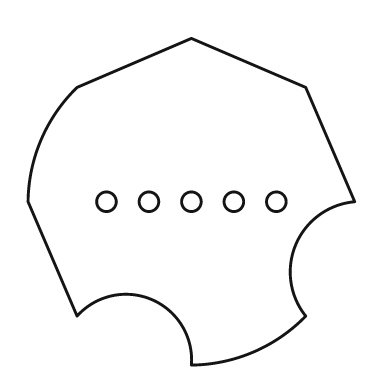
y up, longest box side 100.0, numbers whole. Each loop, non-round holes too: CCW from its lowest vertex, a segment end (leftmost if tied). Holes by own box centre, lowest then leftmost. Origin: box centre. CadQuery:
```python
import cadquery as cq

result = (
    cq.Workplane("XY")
    .moveTo(0.0, -50.0)
    .threePointArc((19.0, -46.0), (35.0, -35.0))
    .threePointArc((32.0, -13.0), (50.0, 0.0))
    .lineTo(35.0, 35.0)
    .lineTo(0.0, 50.0)
    .lineTo(-35.0, 35.0)
    .threePointArc((-46.0, 19.0), (-50.0, 0.0))
    .lineTo(-35.0, -35.0)
    .threePointArc((-12.0, -30.0), (0.0, -50.0))
    .close()
    .moveTo(-26.0, 0.0)
    .circle(3.0)
    .moveTo(-13.0, 0.0)
    .circle(3.0)
    .moveTo(0.0, 0.0)
    .circle(3.0)
    .moveTo(13.0, 0.0)
    .circle(3.0)
    .moveTo(26.0, 0.0)
    .circle(3.0)
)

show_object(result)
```